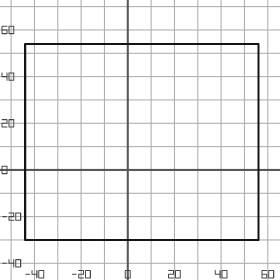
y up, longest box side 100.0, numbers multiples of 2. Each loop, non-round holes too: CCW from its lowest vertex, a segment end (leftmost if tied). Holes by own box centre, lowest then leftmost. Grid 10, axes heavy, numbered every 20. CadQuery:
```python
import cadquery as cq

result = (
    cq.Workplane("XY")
    .moveTo(-44.0, -30.0)
    .lineTo(56.0, -30.0)
    .lineTo(56.0, 54.0)
    .lineTo(-44.0, 54.0)
    .close()
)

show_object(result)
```